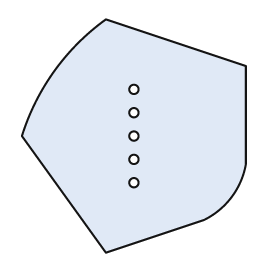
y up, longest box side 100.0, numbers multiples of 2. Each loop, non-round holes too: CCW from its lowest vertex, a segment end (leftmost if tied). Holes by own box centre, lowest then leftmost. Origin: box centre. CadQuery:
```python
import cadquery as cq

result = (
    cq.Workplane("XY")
    .moveTo(-12.0, -50.0)
    .lineTo(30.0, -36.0)
    .threePointArc((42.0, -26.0), (48.0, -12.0))
    .lineTo(48.0, 30.0)
    .lineTo(-12.0, 50.0)
    .threePointArc((-34.0, 28.0), (-48.0, 0.0))
    .close()
    .moveTo(0.0, -20.0)
    .circle(2.0)
    .moveTo(0.0, -10.0)
    .circle(2.0)
    .moveTo(0.0, 0.0)
    .circle(2.0)
    .moveTo(0.0, 10.0)
    .circle(2.0)
    .moveTo(0.0, 20.0)
    .circle(2.0)
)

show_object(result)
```